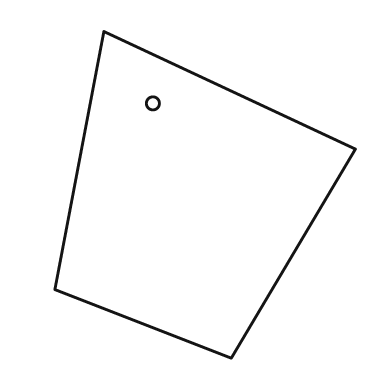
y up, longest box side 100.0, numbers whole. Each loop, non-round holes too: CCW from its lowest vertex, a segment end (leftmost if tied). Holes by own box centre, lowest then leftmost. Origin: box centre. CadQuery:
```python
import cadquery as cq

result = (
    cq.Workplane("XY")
    .moveTo(8.0, -50.0)
    .lineTo(46.0, 14.0)
    .lineTo(-31.0, 50.0)
    .lineTo(-46.0, -29.0)
    .close()
    .moveTo(-16.0, 28.0)
    .circle(2.0)
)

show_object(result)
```